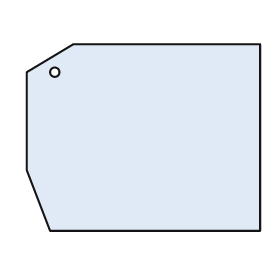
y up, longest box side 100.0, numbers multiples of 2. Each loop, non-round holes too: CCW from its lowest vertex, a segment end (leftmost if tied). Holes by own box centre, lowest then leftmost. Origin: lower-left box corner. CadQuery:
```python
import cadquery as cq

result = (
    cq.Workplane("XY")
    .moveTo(10.0, 0.0)
    .lineTo(100.0, 0.0)
    .lineTo(100.0, 80.0)
    .lineTo(20.0, 80.0)
    .lineTo(0.0, 68.0)
    .lineTo(0.0, 26.0)
    .close()
    .moveTo(12.0, 68.0)
    .circle(2.0)
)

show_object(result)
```